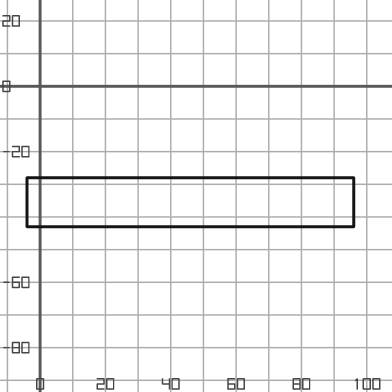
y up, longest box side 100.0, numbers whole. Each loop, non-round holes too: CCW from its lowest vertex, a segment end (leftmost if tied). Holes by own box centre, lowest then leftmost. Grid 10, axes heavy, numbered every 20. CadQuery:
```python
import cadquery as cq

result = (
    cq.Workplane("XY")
    .moveTo(-4.0, -43.0)
    .lineTo(96.0, -43.0)
    .lineTo(96.0, -28.0)
    .lineTo(-4.0, -28.0)
    .close()
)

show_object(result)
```